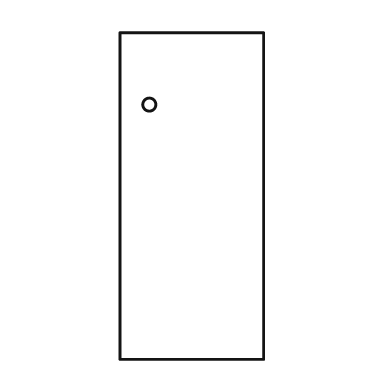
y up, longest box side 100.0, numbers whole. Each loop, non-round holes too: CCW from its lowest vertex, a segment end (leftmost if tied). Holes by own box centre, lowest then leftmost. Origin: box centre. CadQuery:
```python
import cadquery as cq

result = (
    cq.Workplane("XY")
    .moveTo(-22.0, -50.0)
    .lineTo(22.0, -50.0)
    .lineTo(22.0, 50.0)
    .lineTo(-22.0, 50.0)
    .close()
    .moveTo(-13.0, 28.0)
    .circle(2.0)
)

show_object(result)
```